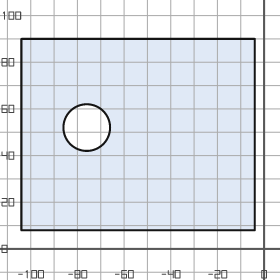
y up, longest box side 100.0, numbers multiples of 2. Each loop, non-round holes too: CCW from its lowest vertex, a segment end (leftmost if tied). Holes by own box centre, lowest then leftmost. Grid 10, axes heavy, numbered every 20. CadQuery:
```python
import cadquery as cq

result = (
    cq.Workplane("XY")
    .moveTo(-104.0, 8.0)
    .lineTo(-4.0, 8.0)
    .lineTo(-4.0, 90.0)
    .lineTo(-104.0, 90.0)
    .close()
    .moveTo(-76.0, 52.0)
    .circle(10.0)
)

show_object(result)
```